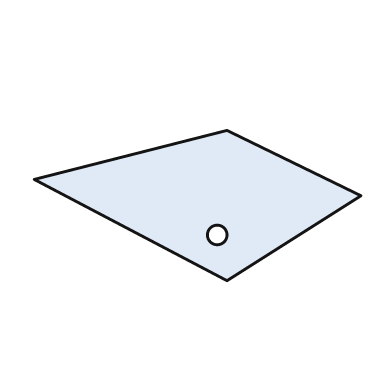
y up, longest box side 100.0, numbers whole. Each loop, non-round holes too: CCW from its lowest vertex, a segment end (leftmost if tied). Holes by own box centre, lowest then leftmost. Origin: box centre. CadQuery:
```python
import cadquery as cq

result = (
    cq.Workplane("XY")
    .moveTo(9.0, -23.0)
    .lineTo(50.0, 3.0)
    .lineTo(9.0, 23.0)
    .lineTo(-50.0, 8.0)
    .close()
    .moveTo(6.0, -9.0)
    .circle(3.0)
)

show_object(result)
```